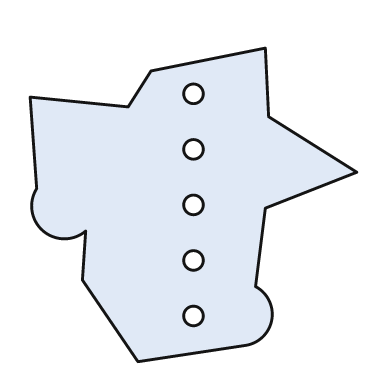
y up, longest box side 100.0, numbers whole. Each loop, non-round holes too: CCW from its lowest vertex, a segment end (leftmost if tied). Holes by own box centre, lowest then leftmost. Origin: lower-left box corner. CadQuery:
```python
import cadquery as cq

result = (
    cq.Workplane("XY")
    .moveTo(33.0, 0.0)
    .lineTo(66.0, 5.0)
    .threePointArc((74.0, 13.0), (69.0, 23.0))
    .lineTo(72.0, 47.0)
    .lineTo(100.0, 58.0)
    .lineTo(73.0, 75.0)
    .lineTo(72.0, 96.0)
    .lineTo(37.0, 89.0)
    .lineTo(30.0, 78.0)
    .lineTo(0.0, 81.0)
    .lineTo(2.0, 53.0)
    .threePointArc((4.0, 40.0), (17.0, 40.0))
    .lineTo(16.0, 25.0)
    .close()
    .moveTo(50.0, 14.0)
    .circle(3.0)
    .moveTo(50.0, 31.0)
    .circle(3.0)
    .moveTo(50.0, 48.0)
    .circle(3.0)
    .moveTo(50.0, 65.0)
    .circle(3.0)
    .moveTo(50.0, 82.0)
    .circle(3.0)
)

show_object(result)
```